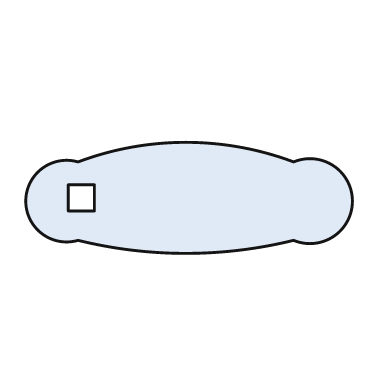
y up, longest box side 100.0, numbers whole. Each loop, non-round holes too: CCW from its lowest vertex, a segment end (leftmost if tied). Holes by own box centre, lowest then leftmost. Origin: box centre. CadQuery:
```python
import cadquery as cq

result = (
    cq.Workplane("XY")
    .moveTo(-34.0, -13.0)
    .threePointArc((-1.0, -17.0), (32.0, -13.0))
    .threePointArc((50.0, -1.0), (32.0, 11.0))
    .threePointArc((-1.0, 17.0), (-34.0, 11.0))
    .threePointArc((-50.0, -1.0), (-34.0, -13.0))
    .close()
    .moveTo(-37.0, -4.0)
    .lineTo(-29.0, -4.0)
    .lineTo(-29.0, 4.0)
    .lineTo(-37.0, 4.0)
    .close()
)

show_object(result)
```